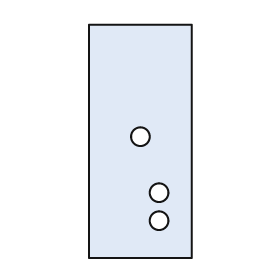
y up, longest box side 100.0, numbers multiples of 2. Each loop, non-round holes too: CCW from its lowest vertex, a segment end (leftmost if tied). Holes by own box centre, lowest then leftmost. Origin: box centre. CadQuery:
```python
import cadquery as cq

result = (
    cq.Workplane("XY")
    .moveTo(-22.0, -50.0)
    .lineTo(22.0, -50.0)
    .lineTo(22.0, 50.0)
    .lineTo(-22.0, 50.0)
    .close()
    .moveTo(8.0, -34.0)
    .circle(4.0)
    .moveTo(8.0, -22.0)
    .circle(4.0)
    .moveTo(0.0, 2.0)
    .circle(4.0)
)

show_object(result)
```